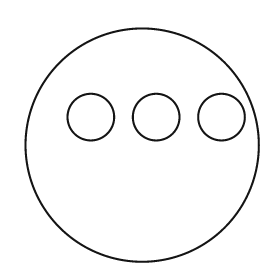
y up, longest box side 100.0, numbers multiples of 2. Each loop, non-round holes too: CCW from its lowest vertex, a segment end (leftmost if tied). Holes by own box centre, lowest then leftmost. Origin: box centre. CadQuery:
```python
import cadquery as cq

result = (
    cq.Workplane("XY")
    .moveTo(0.0, 0.0)
    .circle(50.0)
    .moveTo(-22.0, 12.0)
    .circle(10.0)
    .moveTo(6.0, 12.0)
    .circle(10.0)
    .moveTo(34.0, 12.0)
    .circle(10.0)
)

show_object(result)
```